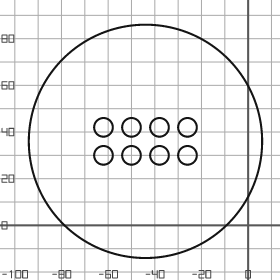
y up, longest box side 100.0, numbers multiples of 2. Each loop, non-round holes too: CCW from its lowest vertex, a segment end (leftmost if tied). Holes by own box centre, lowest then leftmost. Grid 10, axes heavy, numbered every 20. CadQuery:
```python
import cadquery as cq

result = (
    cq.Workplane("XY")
    .moveTo(-44.0, 36.0)
    .circle(50.0)
    .moveTo(-62.0, 30.0)
    .circle(4.0)
    .moveTo(-50.0, 30.0)
    .circle(4.0)
    .moveTo(-38.0, 30.0)
    .circle(4.0)
    .moveTo(-26.0, 30.0)
    .circle(4.0)
    .moveTo(-62.0, 42.0)
    .circle(4.0)
    .moveTo(-50.0, 42.0)
    .circle(4.0)
    .moveTo(-38.0, 42.0)
    .circle(4.0)
    .moveTo(-26.0, 42.0)
    .circle(4.0)
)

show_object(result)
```